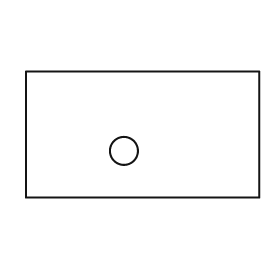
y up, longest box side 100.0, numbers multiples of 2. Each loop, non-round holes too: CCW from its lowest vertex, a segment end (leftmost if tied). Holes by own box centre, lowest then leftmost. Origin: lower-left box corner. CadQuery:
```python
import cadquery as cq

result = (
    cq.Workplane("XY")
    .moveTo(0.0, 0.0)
    .lineTo(100.0, 0.0)
    .lineTo(100.0, 54.0)
    .lineTo(0.0, 54.0)
    .close()
    .moveTo(42.0, 20.0)
    .circle(6.0)
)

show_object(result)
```